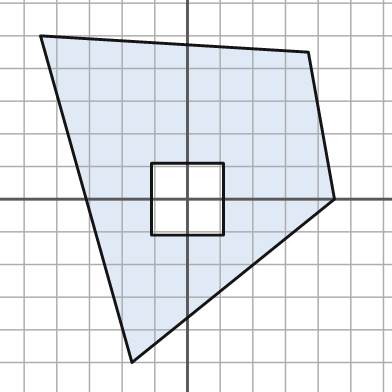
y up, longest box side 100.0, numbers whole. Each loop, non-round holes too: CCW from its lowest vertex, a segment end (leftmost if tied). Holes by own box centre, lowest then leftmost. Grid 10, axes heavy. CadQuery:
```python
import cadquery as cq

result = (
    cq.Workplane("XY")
    .moveTo(-17.0, -50.0)
    .lineTo(45.0, 0.0)
    .lineTo(37.0, 45.0)
    .lineTo(-45.0, 50.0)
    .close()
    .moveTo(-11.0, -11.0)
    .lineTo(11.0, -11.0)
    .lineTo(11.0, 11.0)
    .lineTo(-11.0, 11.0)
    .close()
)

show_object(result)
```